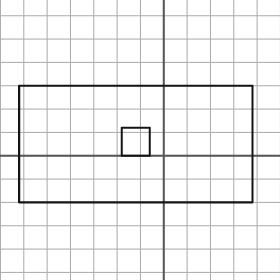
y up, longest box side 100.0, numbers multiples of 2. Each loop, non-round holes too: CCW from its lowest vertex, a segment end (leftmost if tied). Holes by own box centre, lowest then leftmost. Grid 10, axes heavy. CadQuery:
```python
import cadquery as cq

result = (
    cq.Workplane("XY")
    .moveTo(-62.0, -20.0)
    .lineTo(38.0, -20.0)
    .lineTo(38.0, 30.0)
    .lineTo(-62.0, 30.0)
    .close()
    .moveTo(-18.0, 0.0)
    .lineTo(-6.0, 0.0)
    .lineTo(-6.0, 12.0)
    .lineTo(-18.0, 12.0)
    .close()
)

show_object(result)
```